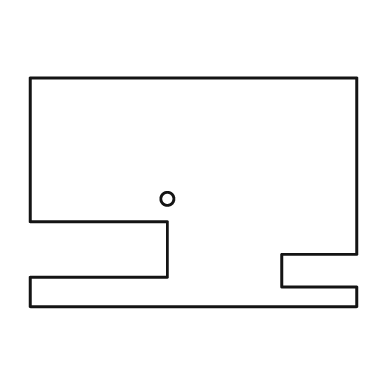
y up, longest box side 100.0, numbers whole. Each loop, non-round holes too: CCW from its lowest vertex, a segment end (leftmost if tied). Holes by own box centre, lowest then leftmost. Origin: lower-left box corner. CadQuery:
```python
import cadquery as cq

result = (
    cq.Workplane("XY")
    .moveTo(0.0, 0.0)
    .lineTo(100.0, 0.0)
    .lineTo(100.0, 6.0)
    .lineTo(77.0, 6.0)
    .lineTo(77.0, 16.0)
    .lineTo(100.0, 16.0)
    .lineTo(100.0, 70.0)
    .lineTo(0.0, 70.0)
    .lineTo(0.0, 26.0)
    .lineTo(42.0, 26.0)
    .lineTo(42.0, 9.0)
    .lineTo(0.0, 9.0)
    .close()
    .moveTo(42.0, 33.0)
    .circle(2.0)
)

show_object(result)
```